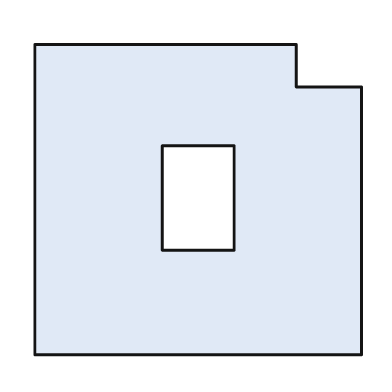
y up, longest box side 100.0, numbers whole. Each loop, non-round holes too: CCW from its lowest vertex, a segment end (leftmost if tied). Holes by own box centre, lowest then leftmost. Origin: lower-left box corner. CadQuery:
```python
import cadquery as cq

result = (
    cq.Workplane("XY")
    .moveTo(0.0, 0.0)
    .lineTo(100.0, 0.0)
    .lineTo(100.0, 82.0)
    .lineTo(80.0, 82.0)
    .lineTo(80.0, 95.0)
    .lineTo(0.0, 95.0)
    .close()
    .moveTo(39.0, 32.0)
    .lineTo(61.0, 32.0)
    .lineTo(61.0, 64.0)
    .lineTo(39.0, 64.0)
    .close()
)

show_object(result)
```